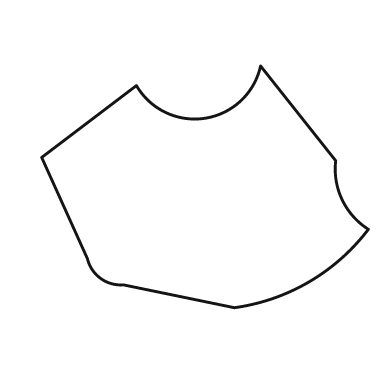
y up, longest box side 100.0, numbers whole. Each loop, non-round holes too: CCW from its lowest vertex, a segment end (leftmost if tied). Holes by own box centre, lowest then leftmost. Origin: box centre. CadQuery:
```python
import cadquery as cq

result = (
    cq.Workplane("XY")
    .moveTo(9.0, -37.0)
    .threePointArc((32.0, -29.0), (50.0, -13.0))
    .threePointArc((42.0, -4.0), (40.0, 8.0))
    .lineTo(17.0, 37.0)
    .threePointArc((0.0, 21.0), (-21.0, 31.0))
    .lineTo(-50.0, 9.0)
    .lineTo(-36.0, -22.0)
    .threePointArc((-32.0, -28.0), (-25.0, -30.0))
    .close()
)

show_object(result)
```